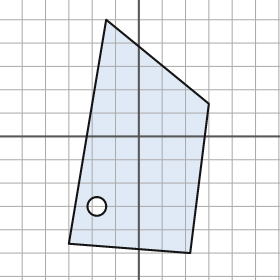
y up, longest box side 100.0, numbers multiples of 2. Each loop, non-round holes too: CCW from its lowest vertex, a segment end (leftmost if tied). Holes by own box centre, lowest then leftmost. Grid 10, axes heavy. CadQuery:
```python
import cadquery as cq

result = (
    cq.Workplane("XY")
    .moveTo(22.0, -50.0)
    .lineTo(30.0, 14.0)
    .lineTo(-14.0, 50.0)
    .lineTo(-30.0, -46.0)
    .close()
    .moveTo(-18.0, -30.0)
    .circle(4.0)
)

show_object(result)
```